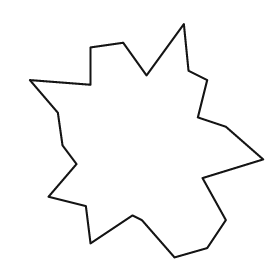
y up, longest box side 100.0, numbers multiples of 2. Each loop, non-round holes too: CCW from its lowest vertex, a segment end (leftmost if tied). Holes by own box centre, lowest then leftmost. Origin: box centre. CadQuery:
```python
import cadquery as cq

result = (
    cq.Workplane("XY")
    .moveTo(12.0, -50.0)
    .lineTo(26.0, -46.0)
    .lineTo(34.0, -34.0)
    .lineTo(24.0, -16.0)
    .lineTo(50.0, -8.0)
    .lineTo(34.0, 6.0)
    .lineTo(22.0, 10.0)
    .lineTo(26.0, 26.0)
    .lineTo(18.0, 30.0)
    .lineTo(16.0, 50.0)
    .lineTo(0.0, 28.0)
    .lineTo(-10.0, 42.0)
    .lineTo(-24.0, 40.0)
    .lineTo(-24.0, 24.0)
    .lineTo(-50.0, 26.0)
    .lineTo(-38.0, 12.0)
    .lineTo(-36.0, -2.0)
    .lineTo(-30.0, -10.0)
    .lineTo(-42.0, -24.0)
    .lineTo(-26.0, -28.0)
    .lineTo(-24.0, -44.0)
    .lineTo(-6.0, -32.0)
    .lineTo(-2.0, -34.0)
    .close()
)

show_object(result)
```